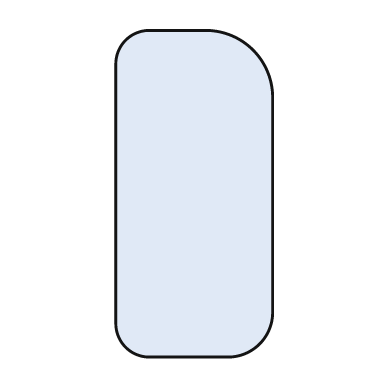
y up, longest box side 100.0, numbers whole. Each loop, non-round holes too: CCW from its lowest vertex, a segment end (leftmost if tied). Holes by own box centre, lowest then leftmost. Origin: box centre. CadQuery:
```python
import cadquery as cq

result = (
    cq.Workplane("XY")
    .moveTo(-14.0, -50.0)
    .lineTo(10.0, -50.0)
    .threePointArc((20.0, -46.0), (24.0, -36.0))
    .lineTo(24.0, 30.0)
    .threePointArc((18.0, 44.0), (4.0, 50.0))
    .lineTo(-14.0, 50.0)
    .threePointArc((-21.0, 47.0), (-24.0, 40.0))
    .lineTo(-24.0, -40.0)
    .threePointArc((-21.0, -47.0), (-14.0, -50.0))
    .close()
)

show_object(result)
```